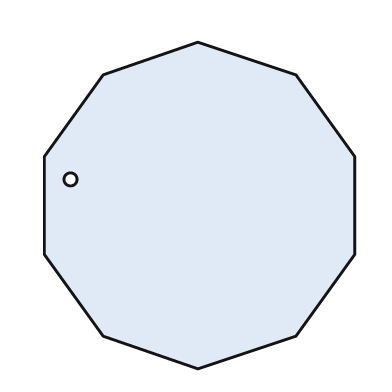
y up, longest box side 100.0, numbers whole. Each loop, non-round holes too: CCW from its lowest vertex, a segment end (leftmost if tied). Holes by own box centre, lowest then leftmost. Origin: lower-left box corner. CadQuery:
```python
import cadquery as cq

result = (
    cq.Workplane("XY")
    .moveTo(47.0, 0.0)
    .lineTo(77.0, 10.0)
    .lineTo(95.0, 35.0)
    .lineTo(95.0, 65.0)
    .lineTo(77.0, 90.0)
    .lineTo(47.0, 100.0)
    .lineTo(18.0, 90.0)
    .lineTo(0.0, 65.0)
    .lineTo(0.0, 35.0)
    .lineTo(18.0, 10.0)
    .close()
    .moveTo(8.0, 58.0)
    .circle(2.0)
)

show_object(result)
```